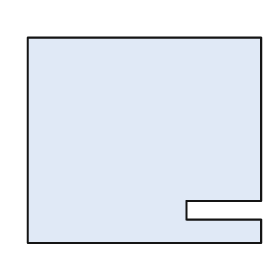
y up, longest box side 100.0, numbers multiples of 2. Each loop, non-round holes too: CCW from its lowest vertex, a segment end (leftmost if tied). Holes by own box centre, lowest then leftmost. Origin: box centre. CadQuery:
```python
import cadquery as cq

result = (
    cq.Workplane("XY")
    .moveTo(-50.0, -44.0)
    .lineTo(50.0, -44.0)
    .lineTo(50.0, -34.0)
    .lineTo(18.0, -34.0)
    .lineTo(18.0, -26.0)
    .lineTo(50.0, -26.0)
    .lineTo(50.0, 44.0)
    .lineTo(-50.0, 44.0)
    .close()
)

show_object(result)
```